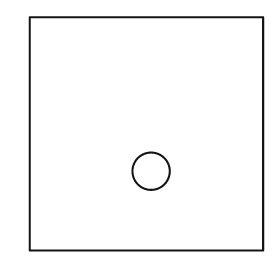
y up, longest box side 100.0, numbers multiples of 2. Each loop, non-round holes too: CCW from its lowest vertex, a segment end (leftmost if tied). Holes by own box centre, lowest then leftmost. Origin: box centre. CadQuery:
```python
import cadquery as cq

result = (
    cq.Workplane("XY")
    .moveTo(-50.0, -50.0)
    .lineTo(50.0, -50.0)
    .lineTo(50.0, 50.0)
    .lineTo(-50.0, 50.0)
    .close()
    .moveTo(2.0, -16.0)
    .circle(8.0)
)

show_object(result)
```